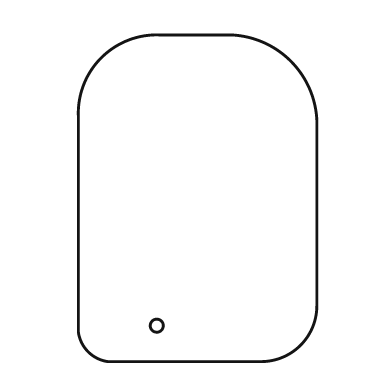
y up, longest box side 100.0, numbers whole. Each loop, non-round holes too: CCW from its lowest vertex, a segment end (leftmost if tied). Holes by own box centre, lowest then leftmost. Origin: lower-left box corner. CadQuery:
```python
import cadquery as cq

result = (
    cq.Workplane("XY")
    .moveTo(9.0, 0.0)
    .lineTo(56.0, 0.0)
    .threePointArc((68.0, 5.0), (73.0, 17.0))
    .lineTo(73.0, 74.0)
    .threePointArc((65.0, 92.0), (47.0, 100.0))
    .lineTo(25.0, 100.0)
    .threePointArc((7.0, 93.0), (0.0, 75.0))
    .lineTo(0.0, 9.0)
    .threePointArc((3.0, 3.0), (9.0, 0.0))
    .close()
    .moveTo(24.0, 11.0)
    .circle(2.0)
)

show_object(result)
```